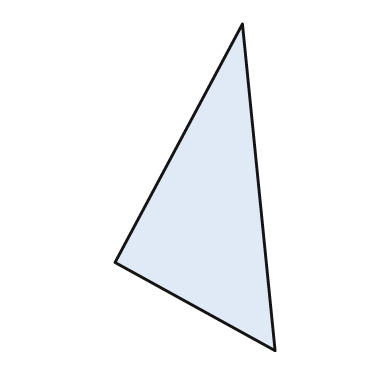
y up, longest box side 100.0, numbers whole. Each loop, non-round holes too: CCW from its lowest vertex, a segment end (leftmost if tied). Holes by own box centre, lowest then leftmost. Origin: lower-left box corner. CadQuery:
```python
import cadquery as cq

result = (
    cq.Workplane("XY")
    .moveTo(49.0, 0.0)
    .lineTo(39.0, 100.0)
    .lineTo(0.0, 27.0)
    .close()
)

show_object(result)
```